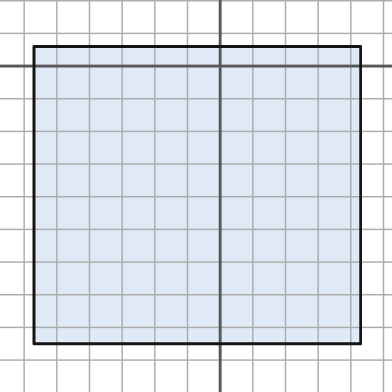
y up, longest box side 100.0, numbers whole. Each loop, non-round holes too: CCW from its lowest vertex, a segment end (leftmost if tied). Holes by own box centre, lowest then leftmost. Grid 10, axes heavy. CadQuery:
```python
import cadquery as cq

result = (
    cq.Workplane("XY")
    .moveTo(-57.0, -85.0)
    .lineTo(43.0, -85.0)
    .lineTo(43.0, 6.0)
    .lineTo(-57.0, 6.0)
    .close()
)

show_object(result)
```